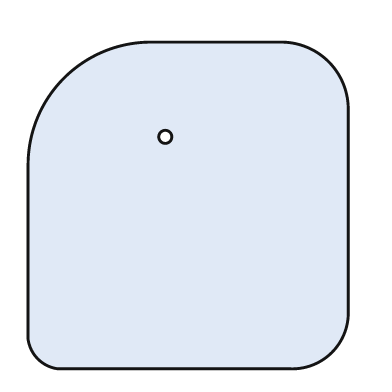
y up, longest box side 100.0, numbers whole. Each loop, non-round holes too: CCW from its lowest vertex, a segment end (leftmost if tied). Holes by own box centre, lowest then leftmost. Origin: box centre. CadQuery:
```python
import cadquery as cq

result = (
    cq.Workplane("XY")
    .moveTo(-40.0, -50.0)
    .lineTo(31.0, -50.0)
    .threePointArc((44.0, -45.0), (49.0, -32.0))
    .lineTo(49.0, 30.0)
    .threePointArc((43.0, 44.0), (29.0, 50.0))
    .lineTo(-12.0, 50.0)
    .threePointArc((-38.0, 39.0), (-49.0, 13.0))
    .lineTo(-49.0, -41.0)
    .threePointArc((-46.0, -47.0), (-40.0, -50.0))
    .close()
    .moveTo(-7.0, 21.0)
    .circle(2.0)
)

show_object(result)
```